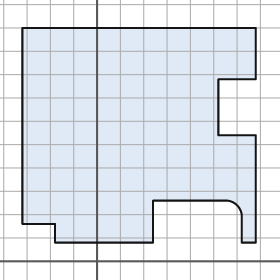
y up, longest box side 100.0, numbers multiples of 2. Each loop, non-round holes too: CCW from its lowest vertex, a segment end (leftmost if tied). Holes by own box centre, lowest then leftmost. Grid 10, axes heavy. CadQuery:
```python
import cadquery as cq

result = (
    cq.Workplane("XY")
    .moveTo(-18.0, 8.0)
    .lineTo(24.0, 8.0)
    .lineTo(24.0, 26.0)
    .lineTo(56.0, 26.0)
    .threePointArc((60.0, 24.0), (62.0, 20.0))
    .lineTo(62.0, 8.0)
    .lineTo(68.0, 8.0)
    .lineTo(68.0, 54.0)
    .lineTo(52.0, 54.0)
    .lineTo(52.0, 78.0)
    .lineTo(68.0, 78.0)
    .lineTo(68.0, 100.0)
    .lineTo(-32.0, 100.0)
    .lineTo(-32.0, 16.0)
    .lineTo(-18.0, 16.0)
    .close()
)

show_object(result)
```